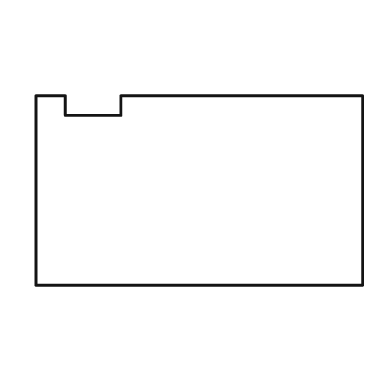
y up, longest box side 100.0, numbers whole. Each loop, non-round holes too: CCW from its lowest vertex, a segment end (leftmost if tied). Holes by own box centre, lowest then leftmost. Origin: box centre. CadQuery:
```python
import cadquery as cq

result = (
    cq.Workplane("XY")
    .moveTo(-50.0, -29.0)
    .lineTo(50.0, -29.0)
    .lineTo(50.0, 29.0)
    .lineTo(-24.0, 29.0)
    .lineTo(-24.0, 23.0)
    .lineTo(-41.0, 23.0)
    .lineTo(-41.0, 29.0)
    .lineTo(-50.0, 29.0)
    .close()
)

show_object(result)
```